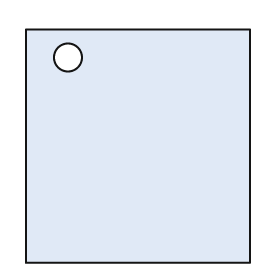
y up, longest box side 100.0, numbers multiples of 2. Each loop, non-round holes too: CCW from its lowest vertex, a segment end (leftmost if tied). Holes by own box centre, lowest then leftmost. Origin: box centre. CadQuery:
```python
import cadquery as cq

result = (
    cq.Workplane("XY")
    .moveTo(-48.0, -50.0)
    .lineTo(48.0, -50.0)
    .lineTo(48.0, 50.0)
    .lineTo(-48.0, 50.0)
    .close()
    .moveTo(-30.0, 38.0)
    .circle(6.0)
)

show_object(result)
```